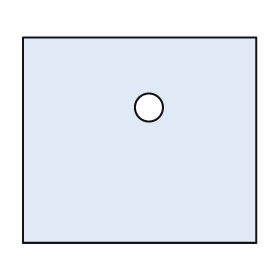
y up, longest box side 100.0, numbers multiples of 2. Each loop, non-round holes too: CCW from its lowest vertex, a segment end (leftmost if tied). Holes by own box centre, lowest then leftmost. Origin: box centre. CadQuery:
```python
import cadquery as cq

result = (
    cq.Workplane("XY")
    .moveTo(-50.0, -44.0)
    .lineTo(50.0, -44.0)
    .lineTo(50.0, 44.0)
    .lineTo(-50.0, 44.0)
    .close()
    .moveTo(4.0, 14.0)
    .circle(6.0)
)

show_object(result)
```